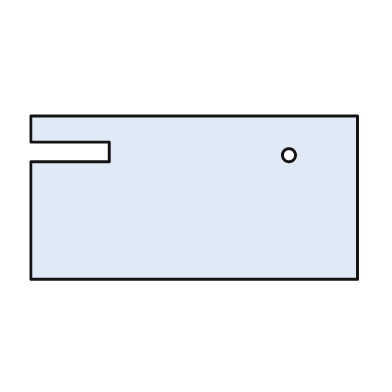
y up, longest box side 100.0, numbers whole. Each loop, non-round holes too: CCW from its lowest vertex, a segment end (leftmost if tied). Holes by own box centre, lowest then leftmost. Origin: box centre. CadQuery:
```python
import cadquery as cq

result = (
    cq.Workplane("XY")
    .moveTo(-50.0, -25.0)
    .lineTo(50.0, -25.0)
    .lineTo(50.0, 25.0)
    .lineTo(-50.0, 25.0)
    .lineTo(-50.0, 17.0)
    .lineTo(-26.0, 17.0)
    .lineTo(-26.0, 11.0)
    .lineTo(-50.0, 11.0)
    .close()
    .moveTo(29.0, 13.0)
    .circle(2.0)
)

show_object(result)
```